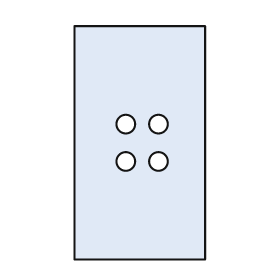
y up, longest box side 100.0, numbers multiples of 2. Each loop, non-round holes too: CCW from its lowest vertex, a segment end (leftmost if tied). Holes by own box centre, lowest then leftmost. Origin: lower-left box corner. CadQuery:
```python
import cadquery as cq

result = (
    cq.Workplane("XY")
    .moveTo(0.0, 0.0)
    .lineTo(56.0, 0.0)
    .lineTo(56.0, 100.0)
    .lineTo(0.0, 100.0)
    .close()
    .moveTo(22.0, 42.0)
    .circle(4.0)
    .moveTo(36.0, 42.0)
    .circle(4.0)
    .moveTo(22.0, 58.0)
    .circle(4.0)
    .moveTo(36.0, 58.0)
    .circle(4.0)
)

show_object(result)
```